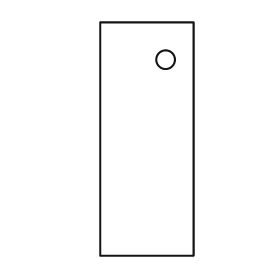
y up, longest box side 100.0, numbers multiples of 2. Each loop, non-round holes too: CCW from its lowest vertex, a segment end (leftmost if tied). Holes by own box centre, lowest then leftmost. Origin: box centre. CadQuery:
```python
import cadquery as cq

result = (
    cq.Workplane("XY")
    .moveTo(-20.0, -50.0)
    .lineTo(20.0, -50.0)
    .lineTo(20.0, 50.0)
    .lineTo(-20.0, 50.0)
    .close()
    .moveTo(8.0, 34.0)
    .circle(4.0)
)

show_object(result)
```